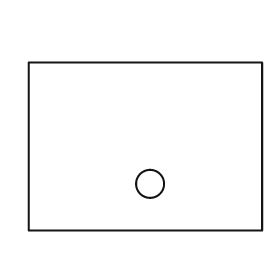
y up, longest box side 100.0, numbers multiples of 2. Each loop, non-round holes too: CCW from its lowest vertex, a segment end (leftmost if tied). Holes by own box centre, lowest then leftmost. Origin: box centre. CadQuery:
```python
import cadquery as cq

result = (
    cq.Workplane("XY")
    .moveTo(-50.0, -36.0)
    .lineTo(50.0, -36.0)
    .lineTo(50.0, 36.0)
    .lineTo(-50.0, 36.0)
    .close()
    .moveTo(2.0, -16.0)
    .circle(6.0)
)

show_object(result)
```